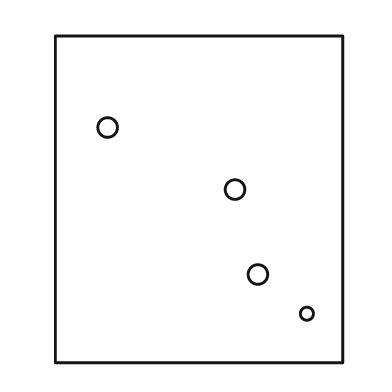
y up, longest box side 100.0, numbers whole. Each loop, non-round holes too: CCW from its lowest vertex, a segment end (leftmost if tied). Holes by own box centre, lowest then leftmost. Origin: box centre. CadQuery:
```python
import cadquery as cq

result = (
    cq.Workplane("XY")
    .moveTo(-44.0, -50.0)
    .lineTo(44.0, -50.0)
    .lineTo(44.0, 50.0)
    .lineTo(-44.0, 50.0)
    .close()
    .moveTo(33.0, -35.0)
    .circle(2.0)
    .moveTo(18.0, -23.0)
    .circle(3.0)
    .moveTo(11.0, 3.0)
    .circle(3.0)
    .moveTo(-28.0, 22.0)
    .circle(3.0)
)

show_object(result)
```